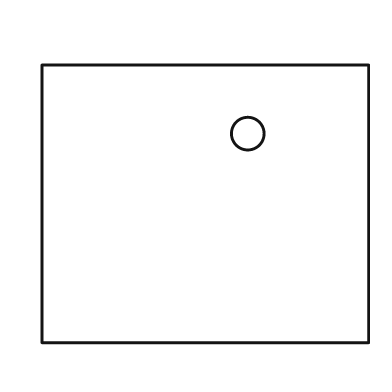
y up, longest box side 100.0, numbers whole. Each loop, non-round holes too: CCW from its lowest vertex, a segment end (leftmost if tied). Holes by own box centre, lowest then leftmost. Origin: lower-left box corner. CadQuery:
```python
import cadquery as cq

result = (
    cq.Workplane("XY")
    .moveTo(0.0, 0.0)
    .lineTo(100.0, 0.0)
    .lineTo(100.0, 85.0)
    .lineTo(0.0, 85.0)
    .close()
    .moveTo(63.0, 64.0)
    .circle(5.0)
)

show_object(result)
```